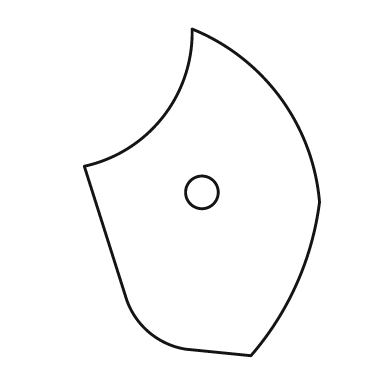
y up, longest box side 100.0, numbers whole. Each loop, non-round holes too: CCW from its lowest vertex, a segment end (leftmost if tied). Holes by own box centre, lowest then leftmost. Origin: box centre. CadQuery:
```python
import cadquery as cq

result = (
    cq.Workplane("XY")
    .moveTo(15.0, -50.0)
    .threePointArc((29.0, -28.0), (36.0, -3.0))
    .threePointArc((24.0, 29.0), (-3.0, 50.0))
    .threePointArc((-12.0, 23.0), (-36.0, 8.0))
    .lineTo(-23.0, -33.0)
    .threePointArc((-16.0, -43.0), (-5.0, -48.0))
    .close()
    .moveTo(0.0, 0.0)
    .circle(5.0)
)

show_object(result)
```